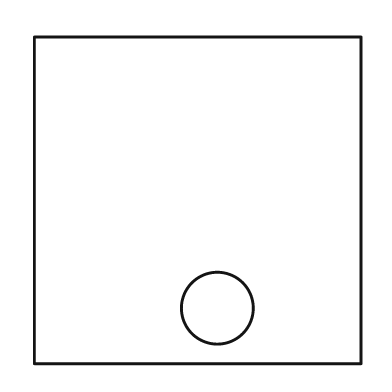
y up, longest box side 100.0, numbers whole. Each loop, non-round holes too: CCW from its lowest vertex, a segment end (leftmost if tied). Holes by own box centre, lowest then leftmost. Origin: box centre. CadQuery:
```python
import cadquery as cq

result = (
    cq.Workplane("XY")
    .moveTo(-50.0, -50.0)
    .lineTo(50.0, -50.0)
    .lineTo(50.0, 50.0)
    .lineTo(-50.0, 50.0)
    .close()
    .moveTo(6.0, -33.0)
    .circle(11.0)
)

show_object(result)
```